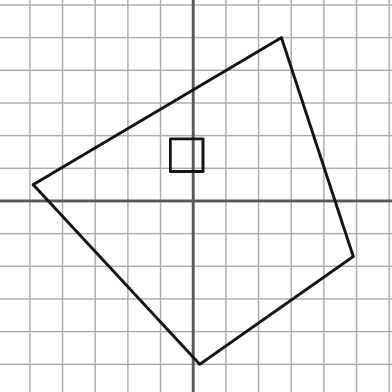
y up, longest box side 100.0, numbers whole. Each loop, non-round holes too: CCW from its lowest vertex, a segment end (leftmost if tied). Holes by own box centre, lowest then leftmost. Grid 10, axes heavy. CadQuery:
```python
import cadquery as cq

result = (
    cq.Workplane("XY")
    .moveTo(2.0, -50.0)
    .lineTo(49.0, -17.0)
    .lineTo(27.0, 50.0)
    .lineTo(-49.0, 5.0)
    .close()
    .moveTo(-7.0, 9.0)
    .lineTo(3.0, 9.0)
    .lineTo(3.0, 19.0)
    .lineTo(-7.0, 19.0)
    .close()
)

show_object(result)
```